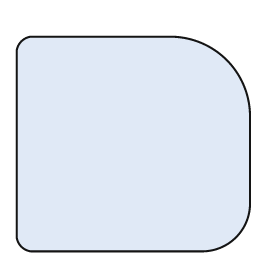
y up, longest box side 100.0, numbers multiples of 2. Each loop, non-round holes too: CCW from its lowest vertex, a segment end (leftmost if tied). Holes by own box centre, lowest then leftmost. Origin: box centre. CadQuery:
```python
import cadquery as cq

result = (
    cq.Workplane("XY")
    .moveTo(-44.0, -46.0)
    .lineTo(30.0, -46.0)
    .threePointArc((44.0, -40.0), (50.0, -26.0))
    .lineTo(50.0, 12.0)
    .threePointArc((40.0, 36.0), (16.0, 46.0))
    .lineTo(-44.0, 46.0)
    .threePointArc((-48.0, 44.0), (-50.0, 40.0))
    .lineTo(-50.0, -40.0)
    .threePointArc((-48.0, -44.0), (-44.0, -46.0))
    .close()
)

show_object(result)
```